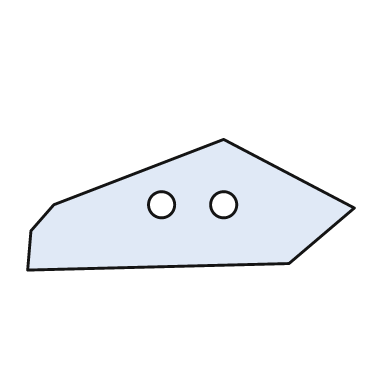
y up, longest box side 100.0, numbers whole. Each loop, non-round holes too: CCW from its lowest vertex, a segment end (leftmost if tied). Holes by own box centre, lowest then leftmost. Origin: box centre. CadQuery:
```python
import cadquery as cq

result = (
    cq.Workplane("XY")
    .moveTo(-50.0, -20.0)
    .lineTo(30.0, -18.0)
    .lineTo(50.0, -1.0)
    .lineTo(10.0, 20.0)
    .lineTo(-42.0, 0.0)
    .lineTo(-49.0, -8.0)
    .close()
    .moveTo(-9.0, 0.0)
    .circle(4.0)
    .moveTo(10.0, 0.0)
    .circle(4.0)
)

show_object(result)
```